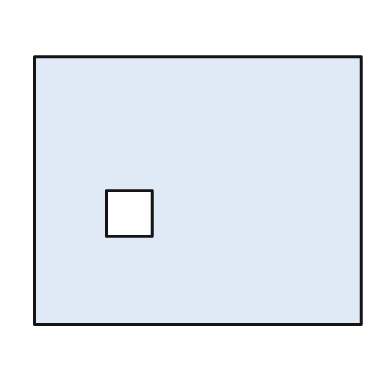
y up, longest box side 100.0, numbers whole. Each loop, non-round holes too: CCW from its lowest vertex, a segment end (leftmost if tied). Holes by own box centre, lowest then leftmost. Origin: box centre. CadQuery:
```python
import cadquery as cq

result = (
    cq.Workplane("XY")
    .moveTo(-50.0, -41.0)
    .lineTo(50.0, -41.0)
    .lineTo(50.0, 41.0)
    .lineTo(-50.0, 41.0)
    .close()
    .moveTo(-28.0, -14.0)
    .lineTo(-14.0, -14.0)
    .lineTo(-14.0, 0.0)
    .lineTo(-28.0, 0.0)
    .close()
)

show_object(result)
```